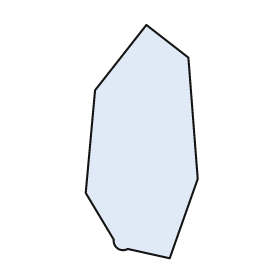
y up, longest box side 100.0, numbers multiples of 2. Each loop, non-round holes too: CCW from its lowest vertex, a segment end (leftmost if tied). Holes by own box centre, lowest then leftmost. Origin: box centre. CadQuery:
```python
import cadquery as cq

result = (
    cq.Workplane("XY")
    .moveTo(12.0, -50.0)
    .lineTo(24.0, -16.0)
    .lineTo(20.0, 36.0)
    .lineTo(2.0, 50.0)
    .lineTo(-20.0, 22.0)
    .lineTo(-24.0, -22.0)
    .lineTo(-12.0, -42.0)
    .threePointArc((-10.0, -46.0), (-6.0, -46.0))
    .close()
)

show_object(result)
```